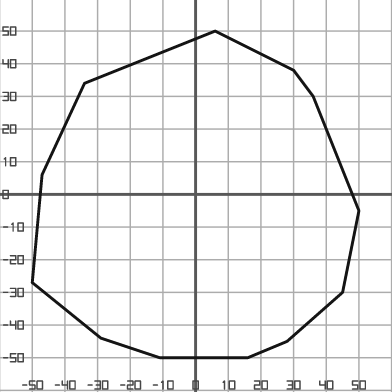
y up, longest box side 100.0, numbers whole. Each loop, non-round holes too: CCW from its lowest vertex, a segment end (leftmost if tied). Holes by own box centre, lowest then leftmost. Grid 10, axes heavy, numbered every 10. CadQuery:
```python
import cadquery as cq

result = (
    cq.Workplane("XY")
    .moveTo(-11.0, -50.0)
    .lineTo(16.0, -50.0)
    .lineTo(28.0, -45.0)
    .lineTo(45.0, -30.0)
    .lineTo(50.0, -5.0)
    .lineTo(36.0, 30.0)
    .lineTo(30.0, 38.0)
    .lineTo(6.0, 50.0)
    .lineTo(-34.0, 34.0)
    .lineTo(-47.0, 6.0)
    .lineTo(-50.0, -27.0)
    .lineTo(-29.0, -44.0)
    .close()
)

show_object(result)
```